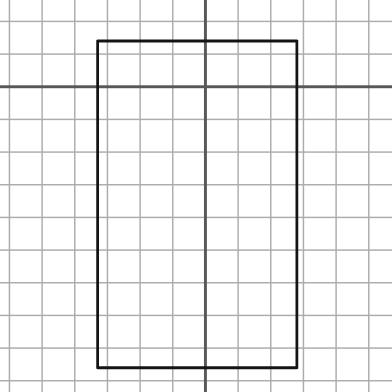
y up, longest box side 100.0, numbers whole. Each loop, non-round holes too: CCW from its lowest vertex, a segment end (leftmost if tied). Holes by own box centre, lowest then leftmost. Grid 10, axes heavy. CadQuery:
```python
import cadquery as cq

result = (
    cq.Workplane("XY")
    .moveTo(-33.0, -86.0)
    .lineTo(28.0, -86.0)
    .lineTo(28.0, 14.0)
    .lineTo(-33.0, 14.0)
    .close()
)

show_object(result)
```